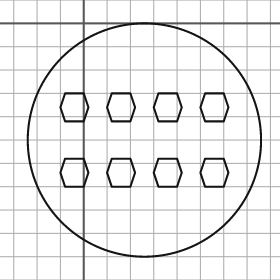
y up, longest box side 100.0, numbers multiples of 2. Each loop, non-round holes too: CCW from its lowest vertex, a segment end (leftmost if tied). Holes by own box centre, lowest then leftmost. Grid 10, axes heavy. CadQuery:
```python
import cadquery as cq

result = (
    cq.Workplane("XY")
    .moveTo(26.0, -50.0)
    .circle(50.0)
    .moveTo(-8.0, -70.0)
    .lineTo(0.0, -70.0)
    .lineTo(2.0, -64.0)
    .lineTo(0.0, -58.0)
    .lineTo(-8.0, -58.0)
    .lineTo(-10.0, -64.0)
    .close()
    .moveTo(12.0, -70.0)
    .lineTo(20.0, -70.0)
    .lineTo(22.0, -64.0)
    .lineTo(20.0, -58.0)
    .lineTo(12.0, -58.0)
    .lineTo(10.0, -64.0)
    .close()
    .moveTo(32.0, -70.0)
    .lineTo(40.0, -70.0)
    .lineTo(42.0, -64.0)
    .lineTo(40.0, -58.0)
    .lineTo(32.0, -58.0)
    .lineTo(30.0, -64.0)
    .close()
    .moveTo(52.0, -70.0)
    .lineTo(60.0, -70.0)
    .lineTo(62.0, -64.0)
    .lineTo(60.0, -58.0)
    .lineTo(52.0, -58.0)
    .lineTo(50.0, -64.0)
    .close()
    .moveTo(-8.0, -42.0)
    .lineTo(0.0, -42.0)
    .lineTo(2.0, -36.0)
    .lineTo(0.0, -30.0)
    .lineTo(-8.0, -30.0)
    .lineTo(-10.0, -36.0)
    .close()
    .moveTo(12.0, -42.0)
    .lineTo(20.0, -42.0)
    .lineTo(22.0, -36.0)
    .lineTo(20.0, -30.0)
    .lineTo(12.0, -30.0)
    .lineTo(10.0, -36.0)
    .close()
    .moveTo(32.0, -42.0)
    .lineTo(40.0, -42.0)
    .lineTo(42.0, -36.0)
    .lineTo(40.0, -30.0)
    .lineTo(32.0, -30.0)
    .lineTo(30.0, -36.0)
    .close()
    .moveTo(52.0, -42.0)
    .lineTo(60.0, -42.0)
    .lineTo(62.0, -36.0)
    .lineTo(60.0, -30.0)
    .lineTo(52.0, -30.0)
    .lineTo(50.0, -36.0)
    .close()
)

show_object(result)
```